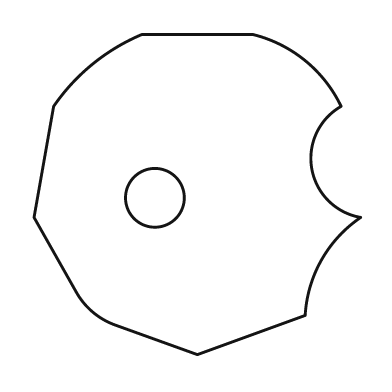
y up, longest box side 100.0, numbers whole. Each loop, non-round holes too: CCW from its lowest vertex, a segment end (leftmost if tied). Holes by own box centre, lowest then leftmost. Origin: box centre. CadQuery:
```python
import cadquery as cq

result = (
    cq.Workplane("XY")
    .moveTo(0.0, -49.0)
    .lineTo(33.0, -37.0)
    .threePointArc((38.0, -20.0), (50.0, -7.0))
    .threePointArc((35.0, 8.0), (44.0, 27.0))
    .threePointArc((33.0, 41.0), (17.0, 49.0))
    .lineTo(-17.0, 49.0)
    .threePointArc((-32.0, 40.0), (-44.0, 27.0))
    .lineTo(-50.0, -7.0)
    .lineTo(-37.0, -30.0)
    .threePointArc((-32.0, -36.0), (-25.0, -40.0))
    .close()
    .moveTo(-13.0, -1.0)
    .circle(9.0)
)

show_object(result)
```